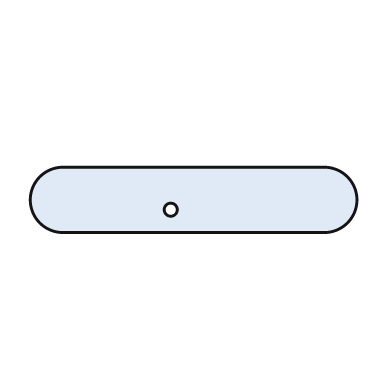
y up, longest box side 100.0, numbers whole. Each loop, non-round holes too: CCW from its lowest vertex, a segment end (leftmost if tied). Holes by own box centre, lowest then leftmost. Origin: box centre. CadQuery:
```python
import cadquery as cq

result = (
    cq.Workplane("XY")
    .moveTo(-40.0, -10.0)
    .lineTo(40.0, -10.0)
    .threePointArc((50.0, 0.0), (40.0, 10.0))
    .lineTo(-40.0, 10.0)
    .threePointArc((-50.0, 0.0), (-40.0, -10.0))
    .close()
    .moveTo(-7.0, -3.0)
    .circle(2.0)
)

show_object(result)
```